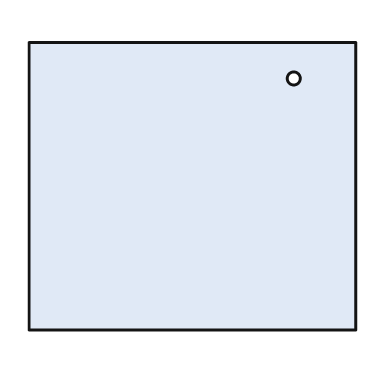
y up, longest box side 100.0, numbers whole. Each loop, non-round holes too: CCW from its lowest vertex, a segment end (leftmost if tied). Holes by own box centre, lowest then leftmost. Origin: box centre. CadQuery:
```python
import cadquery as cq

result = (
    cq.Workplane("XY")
    .moveTo(-50.0, -44.0)
    .lineTo(50.0, -44.0)
    .lineTo(50.0, 44.0)
    .lineTo(-50.0, 44.0)
    .close()
    .moveTo(31.0, 33.0)
    .circle(2.0)
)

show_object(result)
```